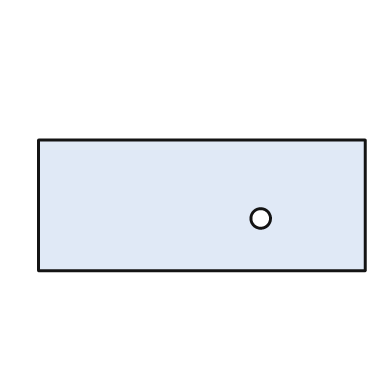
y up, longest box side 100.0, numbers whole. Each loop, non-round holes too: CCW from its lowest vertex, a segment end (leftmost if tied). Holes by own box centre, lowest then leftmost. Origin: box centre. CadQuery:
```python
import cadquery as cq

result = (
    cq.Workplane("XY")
    .moveTo(-50.0, -20.0)
    .lineTo(50.0, -20.0)
    .lineTo(50.0, 20.0)
    .lineTo(-50.0, 20.0)
    .close()
    .moveTo(18.0, -4.0)
    .circle(3.0)
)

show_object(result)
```